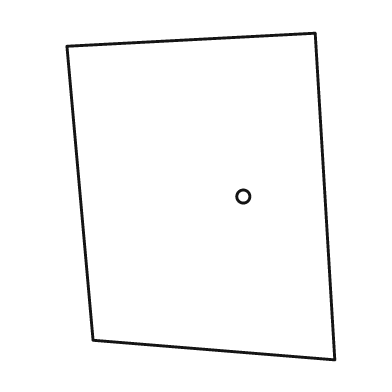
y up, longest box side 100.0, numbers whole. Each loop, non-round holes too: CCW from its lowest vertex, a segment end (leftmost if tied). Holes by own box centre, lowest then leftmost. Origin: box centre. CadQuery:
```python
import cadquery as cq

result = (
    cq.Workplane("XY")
    .moveTo(41.0, -50.0)
    .lineTo(35.0, 50.0)
    .lineTo(-41.0, 46.0)
    .lineTo(-33.0, -44.0)
    .close()
    .moveTo(13.0, 0.0)
    .circle(2.0)
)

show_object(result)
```